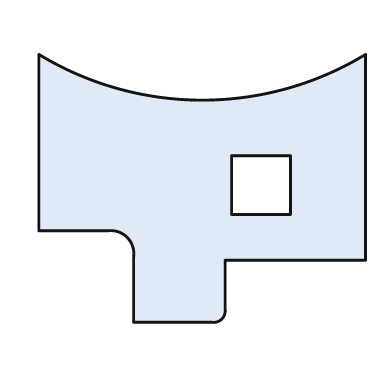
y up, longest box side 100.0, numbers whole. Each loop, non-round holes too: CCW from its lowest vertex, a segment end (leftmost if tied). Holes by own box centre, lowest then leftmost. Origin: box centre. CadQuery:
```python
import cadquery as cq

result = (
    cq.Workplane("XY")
    .moveTo(-21.0, -41.0)
    .lineTo(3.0, -41.0)
    .threePointArc((6.0, -40.0), (7.0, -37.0))
    .lineTo(7.0, -22.0)
    .lineTo(50.0, -22.0)
    .lineTo(50.0, 41.0)
    .threePointArc((0.0, 27.0), (-50.0, 41.0))
    .lineTo(-50.0, -13.0)
    .lineTo(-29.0, -13.0)
    .threePointArc((-23.0, -15.0), (-21.0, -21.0))
    .close()
    .moveTo(9.0, -8.0)
    .lineTo(27.0, -8.0)
    .lineTo(27.0, 10.0)
    .lineTo(9.0, 10.0)
    .close()
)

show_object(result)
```